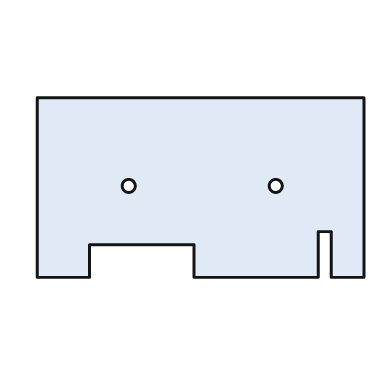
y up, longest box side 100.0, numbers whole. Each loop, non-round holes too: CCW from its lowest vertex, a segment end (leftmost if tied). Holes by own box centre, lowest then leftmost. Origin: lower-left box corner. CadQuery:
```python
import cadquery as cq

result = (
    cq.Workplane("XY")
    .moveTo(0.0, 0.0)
    .lineTo(16.0, 0.0)
    .lineTo(16.0, 10.0)
    .lineTo(48.0, 10.0)
    .lineTo(48.0, 0.0)
    .lineTo(86.0, 0.0)
    .lineTo(86.0, 14.0)
    .lineTo(90.0, 14.0)
    .lineTo(90.0, 0.0)
    .lineTo(100.0, 0.0)
    .lineTo(100.0, 55.0)
    .lineTo(0.0, 55.0)
    .close()
    .moveTo(28.0, 28.0)
    .circle(2.0)
    .moveTo(73.0, 28.0)
    .circle(2.0)
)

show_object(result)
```